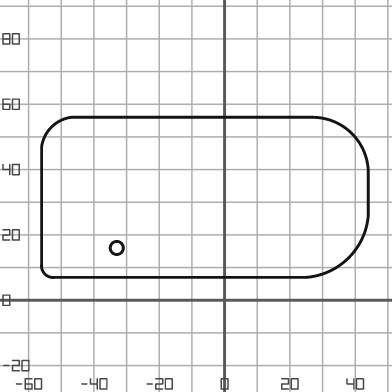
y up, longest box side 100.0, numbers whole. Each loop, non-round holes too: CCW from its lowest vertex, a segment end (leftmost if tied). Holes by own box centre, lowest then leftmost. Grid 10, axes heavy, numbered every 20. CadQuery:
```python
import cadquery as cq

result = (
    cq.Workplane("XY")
    .moveTo(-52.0, 7.0)
    .lineTo(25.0, 7.0)
    .threePointArc((38.0, 13.0), (44.0, 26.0))
    .lineTo(44.0, 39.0)
    .threePointArc((39.0, 51.0), (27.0, 56.0))
    .lineTo(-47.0, 56.0)
    .threePointArc((-53.0, 53.0), (-56.0, 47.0))
    .lineTo(-56.0, 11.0)
    .threePointArc((-55.0, 8.0), (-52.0, 7.0))
    .close()
    .moveTo(-33.0, 16.0)
    .circle(2.0)
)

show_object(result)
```